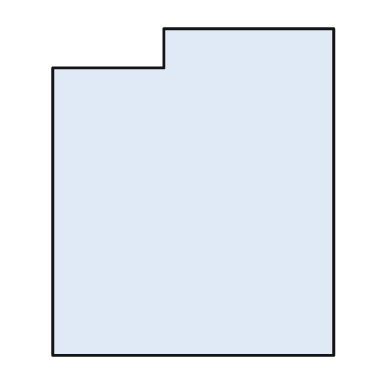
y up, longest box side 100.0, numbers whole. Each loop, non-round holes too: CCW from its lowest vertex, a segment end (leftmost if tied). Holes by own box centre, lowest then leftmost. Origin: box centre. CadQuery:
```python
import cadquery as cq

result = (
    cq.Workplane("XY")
    .moveTo(-43.0, -50.0)
    .lineTo(43.0, -50.0)
    .lineTo(43.0, 50.0)
    .lineTo(-9.0, 50.0)
    .lineTo(-9.0, 38.0)
    .lineTo(-43.0, 38.0)
    .close()
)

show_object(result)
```